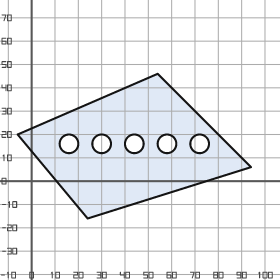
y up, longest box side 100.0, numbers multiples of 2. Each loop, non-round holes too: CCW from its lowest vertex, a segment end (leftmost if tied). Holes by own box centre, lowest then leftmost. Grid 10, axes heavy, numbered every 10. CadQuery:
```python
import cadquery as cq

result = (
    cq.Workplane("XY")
    .moveTo(24.0, -16.0)
    .lineTo(94.0, 6.0)
    .lineTo(54.0, 46.0)
    .lineTo(-6.0, 20.0)
    .close()
    .moveTo(16.0, 16.0)
    .circle(4.0)
    .moveTo(30.0, 16.0)
    .circle(4.0)
    .moveTo(44.0, 16.0)
    .circle(4.0)
    .moveTo(58.0, 16.0)
    .circle(4.0)
    .moveTo(72.0, 16.0)
    .circle(4.0)
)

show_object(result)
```